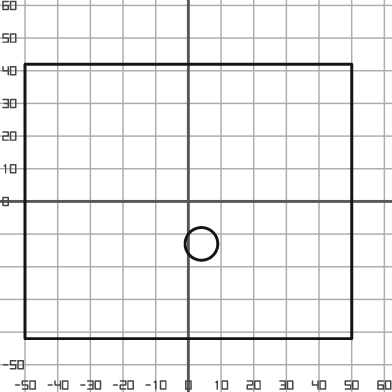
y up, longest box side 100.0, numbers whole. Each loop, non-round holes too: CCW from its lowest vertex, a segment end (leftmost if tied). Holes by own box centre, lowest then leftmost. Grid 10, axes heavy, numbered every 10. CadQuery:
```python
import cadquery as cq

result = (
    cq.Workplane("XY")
    .moveTo(-50.0, -42.0)
    .lineTo(50.0, -42.0)
    .lineTo(50.0, 42.0)
    .lineTo(-50.0, 42.0)
    .close()
    .moveTo(4.0, -13.0)
    .circle(5.0)
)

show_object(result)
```